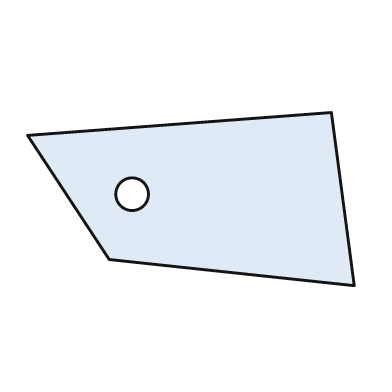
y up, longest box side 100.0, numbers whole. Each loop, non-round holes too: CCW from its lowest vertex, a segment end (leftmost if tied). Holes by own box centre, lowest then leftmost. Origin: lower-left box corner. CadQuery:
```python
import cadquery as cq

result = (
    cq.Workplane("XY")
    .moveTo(100.0, 0.0)
    .lineTo(93.0, 53.0)
    .lineTo(0.0, 46.0)
    .lineTo(25.0, 8.0)
    .close()
    .moveTo(32.0, 28.0)
    .circle(5.0)
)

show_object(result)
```